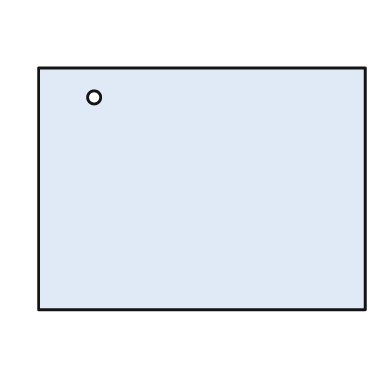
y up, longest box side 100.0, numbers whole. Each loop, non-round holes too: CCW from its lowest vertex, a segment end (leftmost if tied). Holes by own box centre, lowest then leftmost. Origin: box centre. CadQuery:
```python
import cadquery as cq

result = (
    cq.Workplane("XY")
    .moveTo(-50.0, -37.0)
    .lineTo(50.0, -37.0)
    .lineTo(50.0, 37.0)
    .lineTo(-50.0, 37.0)
    .close()
    .moveTo(-33.0, 28.0)
    .circle(2.0)
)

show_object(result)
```